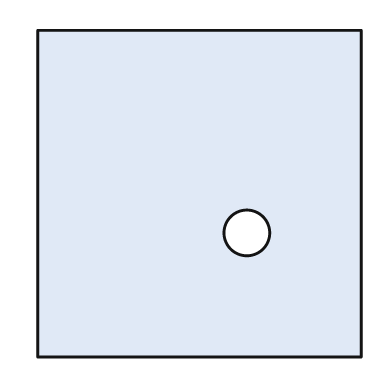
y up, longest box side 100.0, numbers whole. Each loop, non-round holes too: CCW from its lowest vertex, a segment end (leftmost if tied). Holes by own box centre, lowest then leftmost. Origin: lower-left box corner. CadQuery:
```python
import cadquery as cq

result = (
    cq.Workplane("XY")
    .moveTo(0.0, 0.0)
    .lineTo(99.0, 0.0)
    .lineTo(99.0, 100.0)
    .lineTo(0.0, 100.0)
    .close()
    .moveTo(64.0, 38.0)
    .circle(7.0)
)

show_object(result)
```